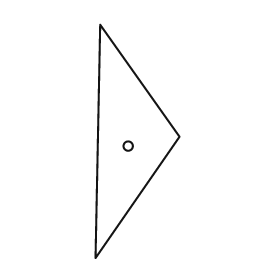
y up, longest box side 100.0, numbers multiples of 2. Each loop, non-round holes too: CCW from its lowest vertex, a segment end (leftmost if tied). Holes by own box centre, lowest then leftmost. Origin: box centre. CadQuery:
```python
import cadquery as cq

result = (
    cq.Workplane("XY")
    .moveTo(-18.0, -50.0)
    .lineTo(18.0, 2.0)
    .lineTo(-16.0, 50.0)
    .close()
    .moveTo(-4.0, -2.0)
    .circle(2.0)
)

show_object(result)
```